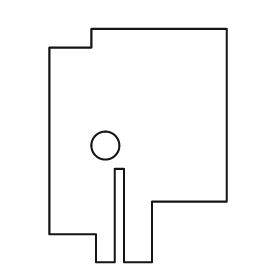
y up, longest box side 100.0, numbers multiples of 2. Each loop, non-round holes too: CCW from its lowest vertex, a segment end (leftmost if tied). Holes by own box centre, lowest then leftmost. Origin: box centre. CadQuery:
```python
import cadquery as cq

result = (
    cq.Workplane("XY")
    .moveTo(-18.0, -50.0)
    .lineTo(-10.0, -50.0)
    .lineTo(-10.0, -10.0)
    .lineTo(-6.0, -10.0)
    .lineTo(-6.0, -50.0)
    .lineTo(6.0, -50.0)
    .lineTo(6.0, -24.0)
    .lineTo(38.0, -24.0)
    .lineTo(38.0, 50.0)
    .lineTo(-20.0, 50.0)
    .lineTo(-20.0, 42.0)
    .lineTo(-38.0, 42.0)
    .lineTo(-38.0, -38.0)
    .lineTo(-18.0, -38.0)
    .close()
    .moveTo(-14.0, 0.0)
    .circle(6.0)
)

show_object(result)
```